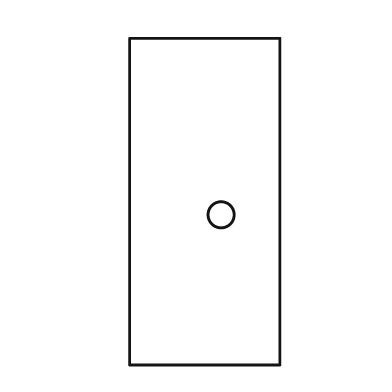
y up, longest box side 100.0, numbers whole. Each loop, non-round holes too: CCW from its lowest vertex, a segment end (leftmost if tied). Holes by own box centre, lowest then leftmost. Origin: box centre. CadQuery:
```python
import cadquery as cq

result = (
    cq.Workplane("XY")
    .moveTo(-23.0, -50.0)
    .lineTo(23.0, -50.0)
    .lineTo(23.0, 50.0)
    .lineTo(-23.0, 50.0)
    .close()
    .moveTo(5.0, -4.0)
    .circle(4.0)
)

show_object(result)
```